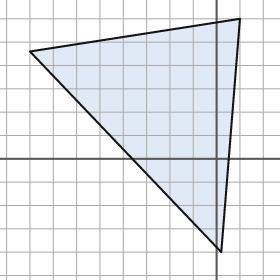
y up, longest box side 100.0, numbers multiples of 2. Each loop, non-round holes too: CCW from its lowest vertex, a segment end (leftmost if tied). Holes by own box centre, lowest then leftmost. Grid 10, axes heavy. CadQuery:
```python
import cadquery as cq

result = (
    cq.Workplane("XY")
    .moveTo(2.0, -40.0)
    .lineTo(10.0, 60.0)
    .lineTo(-80.0, 46.0)
    .close()
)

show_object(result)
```